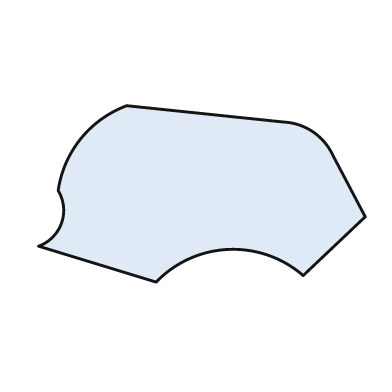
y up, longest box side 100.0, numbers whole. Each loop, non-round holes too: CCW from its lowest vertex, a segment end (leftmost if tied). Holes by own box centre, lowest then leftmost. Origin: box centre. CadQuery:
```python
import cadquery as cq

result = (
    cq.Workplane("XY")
    .moveTo(-14.0, -27.0)
    .threePointArc((8.0, -17.0), (31.0, -25.0))
    .lineTo(50.0, -7.0)
    .lineTo(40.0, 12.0)
    .threePointArc((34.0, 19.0), (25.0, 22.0))
    .lineTo(-23.0, 27.0)
    .threePointArc((-37.0, 17.0), (-44.0, 1.0))
    .threePointArc((-43.0, -9.0), (-50.0, -16.0))
    .close()
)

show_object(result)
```